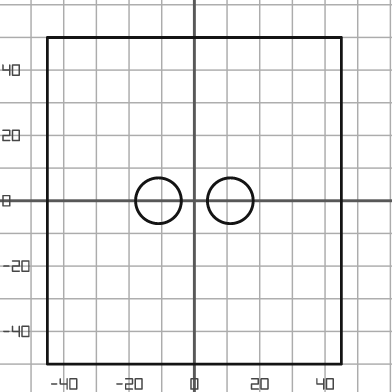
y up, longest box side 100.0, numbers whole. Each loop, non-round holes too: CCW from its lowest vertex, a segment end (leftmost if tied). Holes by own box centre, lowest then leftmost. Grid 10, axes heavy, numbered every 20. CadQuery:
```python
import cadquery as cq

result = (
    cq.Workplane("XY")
    .moveTo(-45.0, -50.0)
    .lineTo(45.0, -50.0)
    .lineTo(45.0, 50.0)
    .lineTo(-45.0, 50.0)
    .close()
    .moveTo(-11.0, 0.0)
    .circle(7.0)
    .moveTo(11.0, 0.0)
    .circle(7.0)
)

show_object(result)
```